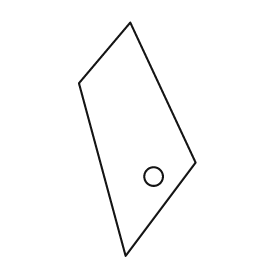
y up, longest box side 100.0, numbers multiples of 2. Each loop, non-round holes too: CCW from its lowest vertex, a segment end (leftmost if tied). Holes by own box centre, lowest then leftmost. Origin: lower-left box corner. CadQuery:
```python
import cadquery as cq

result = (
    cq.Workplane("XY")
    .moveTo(20.0, 0.0)
    .lineTo(50.0, 40.0)
    .lineTo(22.0, 100.0)
    .lineTo(0.0, 74.0)
    .close()
    .moveTo(32.0, 34.0)
    .circle(4.0)
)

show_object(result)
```